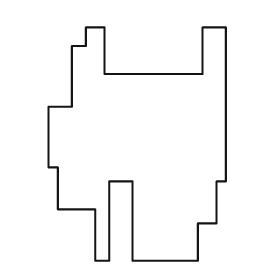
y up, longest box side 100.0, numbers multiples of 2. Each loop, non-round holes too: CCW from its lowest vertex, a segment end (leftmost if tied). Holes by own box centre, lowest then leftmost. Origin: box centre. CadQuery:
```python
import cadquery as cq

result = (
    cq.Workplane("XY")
    .moveTo(-18.0, -50.0)
    .lineTo(-12.0, -50.0)
    .lineTo(-12.0, -16.0)
    .lineTo(-2.0, -16.0)
    .lineTo(-2.0, -50.0)
    .lineTo(26.0, -50.0)
    .lineTo(26.0, -34.0)
    .lineTo(34.0, -34.0)
    .lineTo(34.0, -16.0)
    .lineTo(38.0, -16.0)
    .lineTo(38.0, 50.0)
    .lineTo(28.0, 50.0)
    .lineTo(28.0, 30.0)
    .lineTo(-14.0, 30.0)
    .lineTo(-14.0, 50.0)
    .lineTo(-22.0, 50.0)
    .lineTo(-22.0, 42.0)
    .lineTo(-28.0, 42.0)
    .lineTo(-28.0, 16.0)
    .lineTo(-38.0, 16.0)
    .lineTo(-38.0, -10.0)
    .lineTo(-34.0, -10.0)
    .lineTo(-34.0, -28.0)
    .lineTo(-18.0, -28.0)
    .close()
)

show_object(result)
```